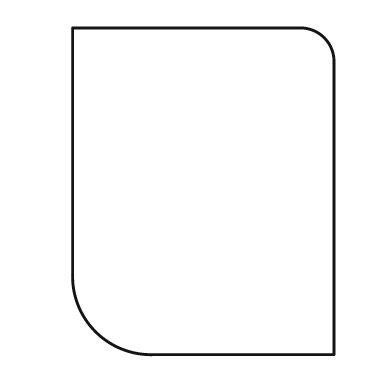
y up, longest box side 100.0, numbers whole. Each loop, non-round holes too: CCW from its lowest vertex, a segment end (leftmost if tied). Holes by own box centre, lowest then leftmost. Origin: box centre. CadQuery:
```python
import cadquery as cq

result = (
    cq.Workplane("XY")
    .moveTo(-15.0, -50.0)
    .lineTo(40.0, -50.0)
    .lineTo(40.0, 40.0)
    .threePointArc((37.0, 47.0), (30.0, 50.0))
    .lineTo(-40.0, 50.0)
    .lineTo(-40.0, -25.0)
    .threePointArc((-33.0, -43.0), (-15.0, -50.0))
    .close()
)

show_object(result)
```